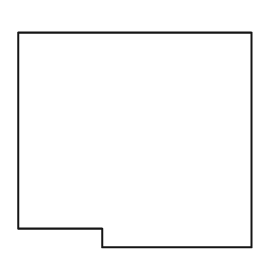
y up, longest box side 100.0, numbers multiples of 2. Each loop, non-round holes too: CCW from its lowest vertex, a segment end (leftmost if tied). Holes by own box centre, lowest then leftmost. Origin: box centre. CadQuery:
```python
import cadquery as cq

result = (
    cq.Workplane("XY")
    .moveTo(-14.0, -46.0)
    .lineTo(50.0, -46.0)
    .lineTo(50.0, 46.0)
    .lineTo(-50.0, 46.0)
    .lineTo(-50.0, -38.0)
    .lineTo(-14.0, -38.0)
    .close()
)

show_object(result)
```